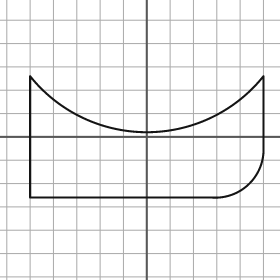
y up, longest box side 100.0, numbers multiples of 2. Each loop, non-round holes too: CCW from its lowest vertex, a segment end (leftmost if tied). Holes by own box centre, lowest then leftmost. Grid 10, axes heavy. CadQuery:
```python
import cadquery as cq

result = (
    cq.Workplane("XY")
    .moveTo(-50.0, -26.0)
    .lineTo(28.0, -26.0)
    .threePointArc((44.0, -20.0), (50.0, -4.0))
    .lineTo(50.0, 26.0)
    .threePointArc((0.0, 2.0), (-50.0, 26.0))
    .close()
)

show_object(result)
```